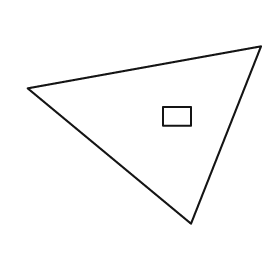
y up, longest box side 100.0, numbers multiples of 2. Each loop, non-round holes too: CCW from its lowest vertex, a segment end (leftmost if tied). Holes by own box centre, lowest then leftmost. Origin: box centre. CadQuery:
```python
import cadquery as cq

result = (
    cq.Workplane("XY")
    .moveTo(20.0, -38.0)
    .lineTo(50.0, 38.0)
    .lineTo(-50.0, 20.0)
    .close()
    .moveTo(8.0, 4.0)
    .lineTo(20.0, 4.0)
    .lineTo(20.0, 12.0)
    .lineTo(8.0, 12.0)
    .close()
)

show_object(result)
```